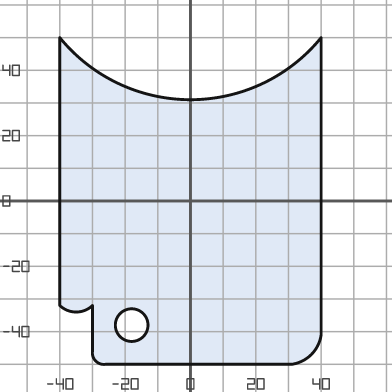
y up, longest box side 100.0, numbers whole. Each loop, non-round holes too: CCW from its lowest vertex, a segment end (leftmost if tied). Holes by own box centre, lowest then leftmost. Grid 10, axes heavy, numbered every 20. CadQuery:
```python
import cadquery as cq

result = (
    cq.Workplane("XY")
    .moveTo(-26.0, -50.0)
    .lineTo(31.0, -50.0)
    .threePointArc((37.0, -47.0), (40.0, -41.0))
    .lineTo(40.0, 50.0)
    .threePointArc((0.0, 31.0), (-40.0, 50.0))
    .lineTo(-40.0, -32.0)
    .threePointArc((-35.0, -34.0), (-30.0, -32.0))
    .lineTo(-30.0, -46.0)
    .threePointArc((-29.0, -49.0), (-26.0, -50.0))
    .close()
    .moveTo(-18.0, -38.0)
    .circle(5.0)
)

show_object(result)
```